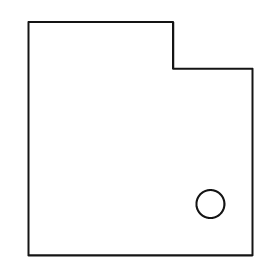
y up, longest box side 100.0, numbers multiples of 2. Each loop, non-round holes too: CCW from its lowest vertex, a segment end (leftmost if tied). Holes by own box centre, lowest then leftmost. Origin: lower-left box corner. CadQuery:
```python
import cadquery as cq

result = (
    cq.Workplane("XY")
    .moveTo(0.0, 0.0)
    .lineTo(96.0, 0.0)
    .lineTo(96.0, 80.0)
    .lineTo(62.0, 80.0)
    .lineTo(62.0, 100.0)
    .lineTo(0.0, 100.0)
    .close()
    .moveTo(78.0, 22.0)
    .circle(6.0)
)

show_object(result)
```